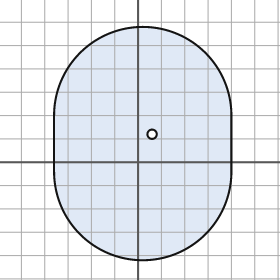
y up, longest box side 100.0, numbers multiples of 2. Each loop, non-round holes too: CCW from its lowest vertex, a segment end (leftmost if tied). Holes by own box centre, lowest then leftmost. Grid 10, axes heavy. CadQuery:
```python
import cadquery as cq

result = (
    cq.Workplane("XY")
    .moveTo(-36.0, -4.0)
    .threePointArc((2.0, -42.0), (40.0, -4.0))
    .lineTo(40.0, 20.0)
    .threePointArc((2.0, 58.0), (-36.0, 20.0))
    .close()
    .moveTo(6.0, 12.0)
    .circle(2.0)
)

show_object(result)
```